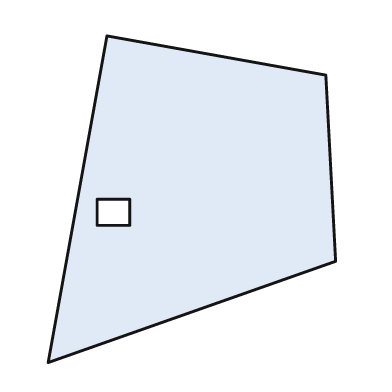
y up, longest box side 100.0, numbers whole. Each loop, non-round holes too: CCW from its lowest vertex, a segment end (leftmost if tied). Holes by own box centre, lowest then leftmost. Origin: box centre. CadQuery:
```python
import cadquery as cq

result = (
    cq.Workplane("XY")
    .moveTo(-44.0, -50.0)
    .lineTo(44.0, -19.0)
    .lineTo(41.0, 38.0)
    .lineTo(-26.0, 50.0)
    .close()
    .moveTo(-29.0, -8.0)
    .lineTo(-19.0, -8.0)
    .lineTo(-19.0, 0.0)
    .lineTo(-29.0, 0.0)
    .close()
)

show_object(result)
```